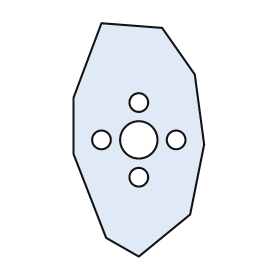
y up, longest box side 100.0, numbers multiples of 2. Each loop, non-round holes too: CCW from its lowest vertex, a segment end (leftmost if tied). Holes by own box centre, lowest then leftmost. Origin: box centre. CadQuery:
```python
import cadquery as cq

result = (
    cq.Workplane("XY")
    .moveTo(0.0, -50.0)
    .lineTo(22.0, -32.0)
    .lineTo(28.0, -2.0)
    .lineTo(24.0, 28.0)
    .lineTo(10.0, 48.0)
    .lineTo(-16.0, 50.0)
    .lineTo(-28.0, 18.0)
    .lineTo(-28.0, -6.0)
    .lineTo(-14.0, -42.0)
    .close()
    .moveTo(0.0, -16.0)
    .circle(4.0)
    .moveTo(-16.0, 0.0)
    .circle(4.0)
    .moveTo(0.0, 0.0)
    .circle(8.0)
    .moveTo(16.0, 0.0)
    .circle(4.0)
    .moveTo(0.0, 16.0)
    .circle(4.0)
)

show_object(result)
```